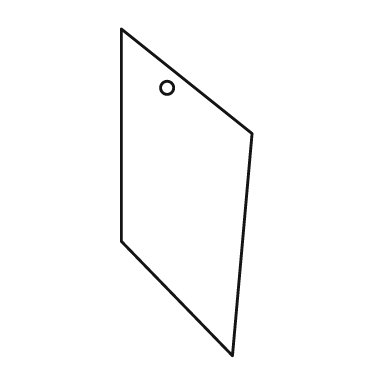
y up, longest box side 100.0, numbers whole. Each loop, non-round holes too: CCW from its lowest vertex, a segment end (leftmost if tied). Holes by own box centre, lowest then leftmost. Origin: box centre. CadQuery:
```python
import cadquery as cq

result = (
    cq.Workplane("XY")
    .moveTo(14.0, -50.0)
    .lineTo(20.0, 18.0)
    .lineTo(-20.0, 50.0)
    .lineTo(-20.0, -15.0)
    .close()
    .moveTo(-6.0, 32.0)
    .circle(2.0)
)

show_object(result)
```